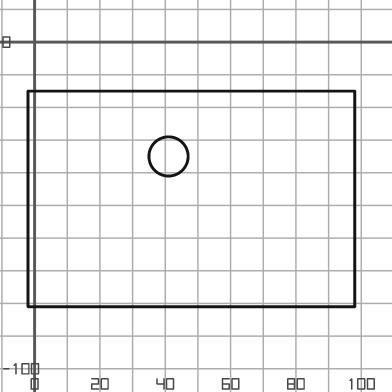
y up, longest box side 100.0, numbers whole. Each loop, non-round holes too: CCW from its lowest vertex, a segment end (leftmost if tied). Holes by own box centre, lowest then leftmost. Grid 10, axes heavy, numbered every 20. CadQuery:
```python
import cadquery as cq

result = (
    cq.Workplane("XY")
    .moveTo(-2.0, -81.0)
    .lineTo(98.0, -81.0)
    .lineTo(98.0, -15.0)
    .lineTo(-2.0, -15.0)
    .close()
    .moveTo(41.0, -35.0)
    .circle(6.0)
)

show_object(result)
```